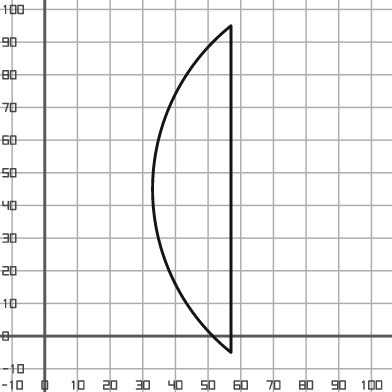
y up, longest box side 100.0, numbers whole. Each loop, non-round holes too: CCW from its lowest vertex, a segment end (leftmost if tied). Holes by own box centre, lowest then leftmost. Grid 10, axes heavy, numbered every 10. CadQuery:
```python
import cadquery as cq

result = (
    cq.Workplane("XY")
    .moveTo(57.0, -5.0)
    .lineTo(57.0, 95.0)
    .threePointArc((33.0, 45.0), (57.0, -5.0))
    .close()
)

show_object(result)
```